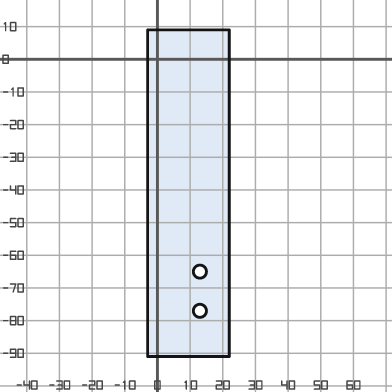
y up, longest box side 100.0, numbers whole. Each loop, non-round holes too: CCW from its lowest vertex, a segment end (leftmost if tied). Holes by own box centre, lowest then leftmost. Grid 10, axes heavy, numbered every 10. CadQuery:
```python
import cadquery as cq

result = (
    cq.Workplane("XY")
    .moveTo(-3.0, -91.0)
    .lineTo(22.0, -91.0)
    .lineTo(22.0, 9.0)
    .lineTo(-3.0, 9.0)
    .close()
    .moveTo(13.0, -77.0)
    .circle(2.0)
    .moveTo(13.0, -65.0)
    .circle(2.0)
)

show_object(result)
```